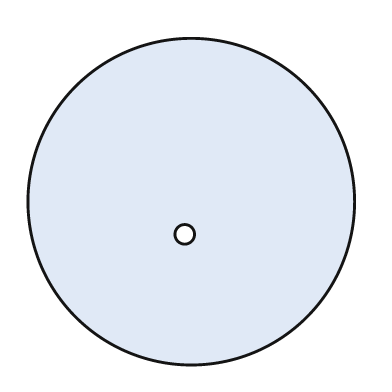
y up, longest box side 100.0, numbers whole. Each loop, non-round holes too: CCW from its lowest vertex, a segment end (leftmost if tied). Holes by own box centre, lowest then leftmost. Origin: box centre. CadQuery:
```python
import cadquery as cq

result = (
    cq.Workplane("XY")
    .moveTo(0.0, 0.0)
    .circle(50.0)
    .moveTo(-2.0, -10.0)
    .circle(3.0)
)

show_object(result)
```